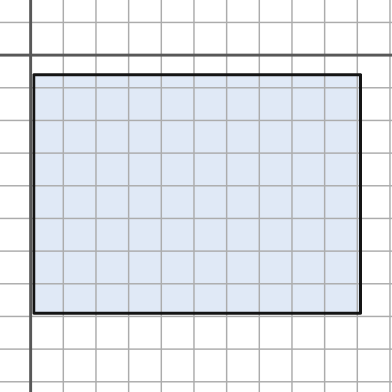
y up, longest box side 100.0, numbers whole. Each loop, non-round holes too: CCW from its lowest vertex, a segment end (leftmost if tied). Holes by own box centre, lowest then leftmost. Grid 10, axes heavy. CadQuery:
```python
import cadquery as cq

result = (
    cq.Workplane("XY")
    .moveTo(1.0, -79.0)
    .lineTo(101.0, -79.0)
    .lineTo(101.0, -6.0)
    .lineTo(1.0, -6.0)
    .close()
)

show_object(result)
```